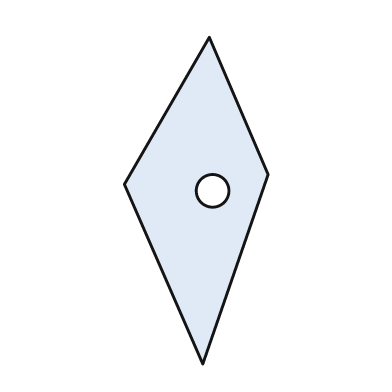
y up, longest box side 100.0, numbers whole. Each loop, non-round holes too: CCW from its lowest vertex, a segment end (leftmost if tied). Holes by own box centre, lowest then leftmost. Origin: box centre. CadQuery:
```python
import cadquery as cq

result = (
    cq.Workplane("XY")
    .moveTo(2.0, -50.0)
    .lineTo(22.0, 8.0)
    .lineTo(4.0, 50.0)
    .lineTo(-22.0, 5.0)
    .close()
    .moveTo(5.0, 3.0)
    .circle(5.0)
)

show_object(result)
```